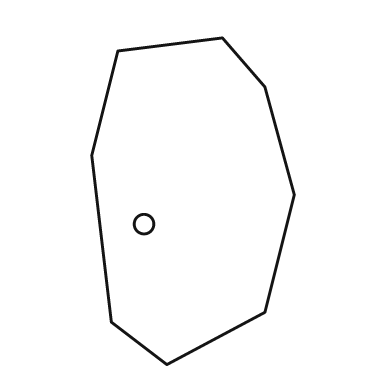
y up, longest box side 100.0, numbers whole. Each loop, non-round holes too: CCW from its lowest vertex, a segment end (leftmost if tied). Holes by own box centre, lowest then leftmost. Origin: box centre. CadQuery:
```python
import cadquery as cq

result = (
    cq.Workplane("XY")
    .moveTo(-8.0, -50.0)
    .lineTo(22.0, -34.0)
    .lineTo(31.0, 2.0)
    .lineTo(22.0, 35.0)
    .lineTo(9.0, 50.0)
    .lineTo(-23.0, 46.0)
    .lineTo(-31.0, 14.0)
    .lineTo(-25.0, -37.0)
    .close()
    .moveTo(-15.0, -7.0)
    .circle(3.0)
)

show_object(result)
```